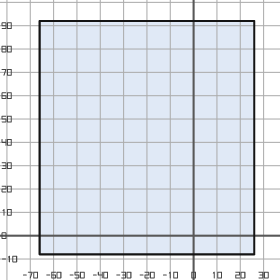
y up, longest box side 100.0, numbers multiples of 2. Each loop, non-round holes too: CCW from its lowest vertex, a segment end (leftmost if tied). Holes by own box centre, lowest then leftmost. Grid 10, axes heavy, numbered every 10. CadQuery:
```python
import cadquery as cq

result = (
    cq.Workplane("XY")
    .moveTo(-66.0, -8.0)
    .lineTo(26.0, -8.0)
    .lineTo(26.0, 92.0)
    .lineTo(-66.0, 92.0)
    .close()
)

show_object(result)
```